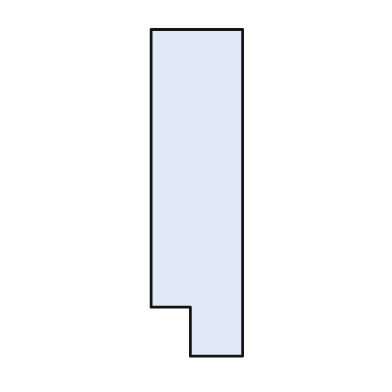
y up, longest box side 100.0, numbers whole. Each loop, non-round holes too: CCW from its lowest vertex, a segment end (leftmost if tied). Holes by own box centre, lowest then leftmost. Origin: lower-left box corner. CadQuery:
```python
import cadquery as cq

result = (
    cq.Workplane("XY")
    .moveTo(12.0, 0.0)
    .lineTo(28.0, 0.0)
    .lineTo(28.0, 100.0)
    .lineTo(0.0, 100.0)
    .lineTo(0.0, 15.0)
    .lineTo(12.0, 15.0)
    .close()
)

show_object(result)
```